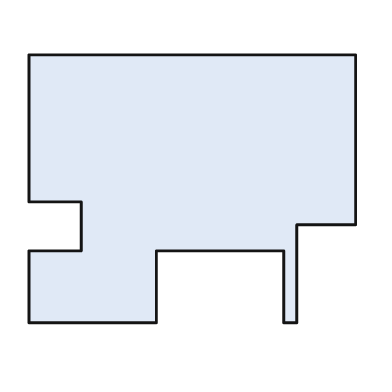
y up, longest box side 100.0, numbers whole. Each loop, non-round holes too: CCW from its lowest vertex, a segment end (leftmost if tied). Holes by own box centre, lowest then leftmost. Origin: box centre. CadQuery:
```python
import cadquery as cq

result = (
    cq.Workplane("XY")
    .moveTo(-50.0, -41.0)
    .lineTo(-11.0, -41.0)
    .lineTo(-11.0, -19.0)
    .lineTo(28.0, -19.0)
    .lineTo(28.0, -41.0)
    .lineTo(32.0, -41.0)
    .lineTo(32.0, -11.0)
    .lineTo(50.0, -11.0)
    .lineTo(50.0, 41.0)
    .lineTo(-50.0, 41.0)
    .lineTo(-50.0, -4.0)
    .lineTo(-34.0, -4.0)
    .lineTo(-34.0, -19.0)
    .lineTo(-50.0, -19.0)
    .close()
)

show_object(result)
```